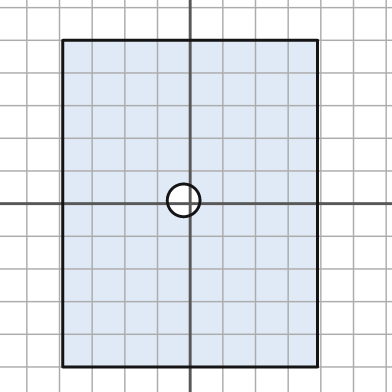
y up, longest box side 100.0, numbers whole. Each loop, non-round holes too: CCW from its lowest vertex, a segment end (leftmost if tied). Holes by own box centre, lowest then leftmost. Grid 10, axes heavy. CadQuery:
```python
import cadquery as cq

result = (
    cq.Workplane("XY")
    .moveTo(-39.0, -50.0)
    .lineTo(39.0, -50.0)
    .lineTo(39.0, 50.0)
    .lineTo(-39.0, 50.0)
    .close()
    .moveTo(-2.0, 1.0)
    .circle(5.0)
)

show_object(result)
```